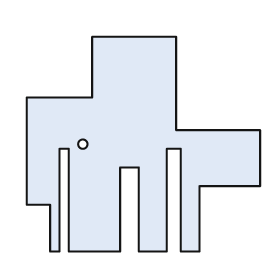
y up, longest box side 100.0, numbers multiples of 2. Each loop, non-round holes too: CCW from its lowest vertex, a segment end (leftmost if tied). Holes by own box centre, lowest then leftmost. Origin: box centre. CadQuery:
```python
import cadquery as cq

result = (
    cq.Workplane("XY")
    .moveTo(-40.0, -46.0)
    .lineTo(-36.0, -46.0)
    .lineTo(-36.0, -2.0)
    .lineTo(-32.0, -2.0)
    .lineTo(-32.0, -46.0)
    .lineTo(-10.0, -46.0)
    .lineTo(-10.0, -10.0)
    .lineTo(-2.0, -10.0)
    .lineTo(-2.0, -46.0)
    .lineTo(10.0, -46.0)
    .lineTo(10.0, -2.0)
    .lineTo(16.0, -2.0)
    .lineTo(16.0, -46.0)
    .lineTo(24.0, -46.0)
    .lineTo(24.0, -18.0)
    .lineTo(50.0, -18.0)
    .lineTo(50.0, 6.0)
    .lineTo(14.0, 6.0)
    .lineTo(14.0, 46.0)
    .lineTo(-22.0, 46.0)
    .lineTo(-22.0, 20.0)
    .lineTo(-50.0, 20.0)
    .lineTo(-50.0, -26.0)
    .lineTo(-40.0, -26.0)
    .close()
    .moveTo(-26.0, 0.0)
    .circle(2.0)
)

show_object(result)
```